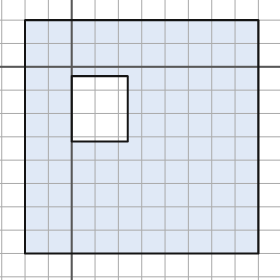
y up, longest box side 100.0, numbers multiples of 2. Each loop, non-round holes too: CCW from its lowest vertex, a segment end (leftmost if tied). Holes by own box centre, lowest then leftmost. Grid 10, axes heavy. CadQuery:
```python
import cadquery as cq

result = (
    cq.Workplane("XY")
    .moveTo(-20.0, -80.0)
    .lineTo(80.0, -80.0)
    .lineTo(80.0, 20.0)
    .lineTo(-20.0, 20.0)
    .close()
    .moveTo(0.0, -32.0)
    .lineTo(24.0, -32.0)
    .lineTo(24.0, -4.0)
    .lineTo(0.0, -4.0)
    .close()
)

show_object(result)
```